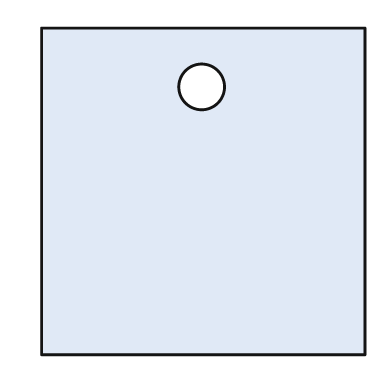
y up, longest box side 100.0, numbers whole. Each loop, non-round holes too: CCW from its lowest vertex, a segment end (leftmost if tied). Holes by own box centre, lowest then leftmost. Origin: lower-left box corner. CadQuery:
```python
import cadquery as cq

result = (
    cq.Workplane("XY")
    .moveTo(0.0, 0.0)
    .lineTo(99.0, 0.0)
    .lineTo(99.0, 100.0)
    .lineTo(0.0, 100.0)
    .close()
    .moveTo(49.0, 82.0)
    .circle(7.0)
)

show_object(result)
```